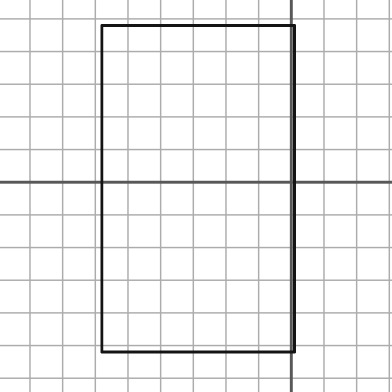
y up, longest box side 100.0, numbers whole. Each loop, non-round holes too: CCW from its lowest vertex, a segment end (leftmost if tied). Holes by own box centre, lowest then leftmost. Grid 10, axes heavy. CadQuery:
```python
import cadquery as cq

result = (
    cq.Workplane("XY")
    .moveTo(-58.0, -52.0)
    .lineTo(1.0, -52.0)
    .lineTo(1.0, 48.0)
    .lineTo(-58.0, 48.0)
    .close()
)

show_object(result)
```